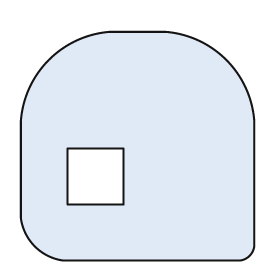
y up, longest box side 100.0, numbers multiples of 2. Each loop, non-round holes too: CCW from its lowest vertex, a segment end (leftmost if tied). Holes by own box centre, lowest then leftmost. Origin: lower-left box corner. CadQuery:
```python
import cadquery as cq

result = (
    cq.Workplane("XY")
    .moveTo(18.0, 0.0)
    .lineTo(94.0, 0.0)
    .threePointArc((98.0, 2.0), (100.0, 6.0))
    .lineTo(100.0, 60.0)
    .threePointArc((88.0, 86.0), (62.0, 98.0))
    .lineTo(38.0, 98.0)
    .threePointArc((12.0, 86.0), (0.0, 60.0))
    .lineTo(0.0, 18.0)
    .threePointArc((6.0, 6.0), (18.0, 0.0))
    .close()
    .moveTo(20.0, 24.0)
    .lineTo(44.0, 24.0)
    .lineTo(44.0, 48.0)
    .lineTo(20.0, 48.0)
    .close()
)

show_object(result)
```